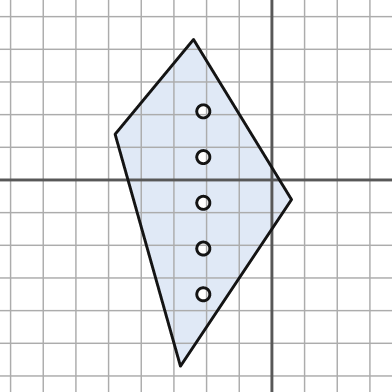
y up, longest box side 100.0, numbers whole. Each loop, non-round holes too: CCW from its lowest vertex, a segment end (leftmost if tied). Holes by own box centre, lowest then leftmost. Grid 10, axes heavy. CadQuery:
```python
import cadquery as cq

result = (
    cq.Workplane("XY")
    .moveTo(-28.0, -57.0)
    .lineTo(6.0, -6.0)
    .lineTo(-24.0, 43.0)
    .lineTo(-48.0, 14.0)
    .close()
    .moveTo(-21.0, -35.0)
    .circle(2.0)
    .moveTo(-21.0, -21.0)
    .circle(2.0)
    .moveTo(-21.0, -7.0)
    .circle(2.0)
    .moveTo(-21.0, 7.0)
    .circle(2.0)
    .moveTo(-21.0, 21.0)
    .circle(2.0)
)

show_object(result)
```